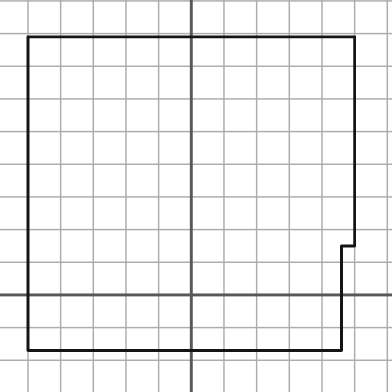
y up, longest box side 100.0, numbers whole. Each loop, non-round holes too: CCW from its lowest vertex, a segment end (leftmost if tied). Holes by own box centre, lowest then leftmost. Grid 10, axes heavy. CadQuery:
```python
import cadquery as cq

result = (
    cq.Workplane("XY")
    .moveTo(-50.0, -17.0)
    .lineTo(46.0, -17.0)
    .lineTo(46.0, 15.0)
    .lineTo(50.0, 15.0)
    .lineTo(50.0, 79.0)
    .lineTo(-50.0, 79.0)
    .close()
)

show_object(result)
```